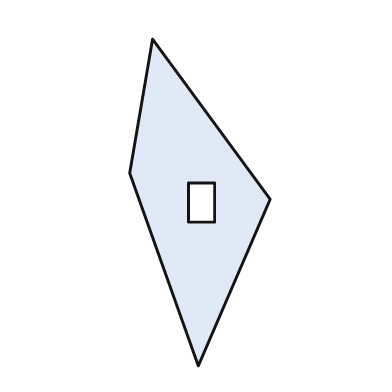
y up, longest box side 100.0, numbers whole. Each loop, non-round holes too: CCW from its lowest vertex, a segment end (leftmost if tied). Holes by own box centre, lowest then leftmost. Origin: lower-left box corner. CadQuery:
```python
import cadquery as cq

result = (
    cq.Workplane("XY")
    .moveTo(21.0, 0.0)
    .lineTo(43.0, 51.0)
    .lineTo(7.0, 100.0)
    .lineTo(0.0, 59.0)
    .close()
    .moveTo(18.0, 44.0)
    .lineTo(26.0, 44.0)
    .lineTo(26.0, 56.0)
    .lineTo(18.0, 56.0)
    .close()
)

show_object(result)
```